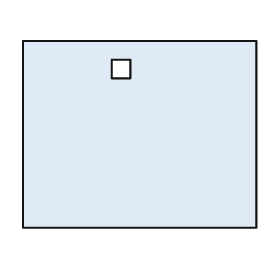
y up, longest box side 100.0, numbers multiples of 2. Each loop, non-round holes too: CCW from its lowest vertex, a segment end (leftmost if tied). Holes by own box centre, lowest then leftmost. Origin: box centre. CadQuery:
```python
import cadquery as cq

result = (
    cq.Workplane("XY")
    .moveTo(-50.0, -40.0)
    .lineTo(50.0, -40.0)
    .lineTo(50.0, 40.0)
    .lineTo(-50.0, 40.0)
    .close()
    .moveTo(-12.0, 24.0)
    .lineTo(-4.0, 24.0)
    .lineTo(-4.0, 32.0)
    .lineTo(-12.0, 32.0)
    .close()
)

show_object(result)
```